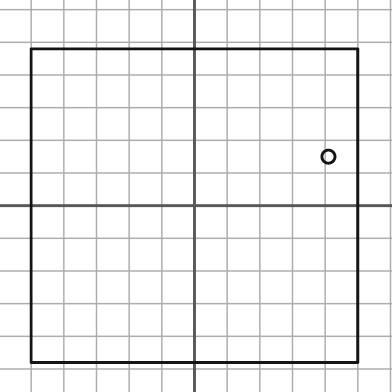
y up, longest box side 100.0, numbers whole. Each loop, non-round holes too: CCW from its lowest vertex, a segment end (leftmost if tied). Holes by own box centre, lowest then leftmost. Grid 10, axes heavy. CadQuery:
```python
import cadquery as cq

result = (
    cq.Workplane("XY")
    .moveTo(-50.0, -48.0)
    .lineTo(50.0, -48.0)
    .lineTo(50.0, 48.0)
    .lineTo(-50.0, 48.0)
    .close()
    .moveTo(41.0, 15.0)
    .circle(2.0)
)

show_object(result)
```